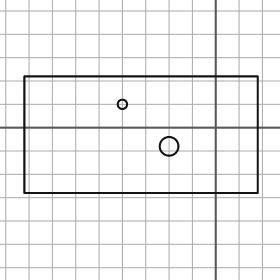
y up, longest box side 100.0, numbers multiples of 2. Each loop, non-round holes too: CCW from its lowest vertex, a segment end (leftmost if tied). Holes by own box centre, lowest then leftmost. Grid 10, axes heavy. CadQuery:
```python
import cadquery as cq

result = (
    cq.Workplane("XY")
    .moveTo(-82.0, -28.0)
    .lineTo(18.0, -28.0)
    .lineTo(18.0, 22.0)
    .lineTo(-82.0, 22.0)
    .close()
    .moveTo(-20.0, -8.0)
    .circle(4.0)
    .moveTo(-40.0, 10.0)
    .circle(2.0)
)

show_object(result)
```